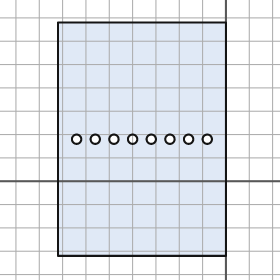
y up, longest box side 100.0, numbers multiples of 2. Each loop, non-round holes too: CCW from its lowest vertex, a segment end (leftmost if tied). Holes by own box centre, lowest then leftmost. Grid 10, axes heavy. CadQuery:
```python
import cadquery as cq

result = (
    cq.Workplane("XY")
    .moveTo(-72.0, -32.0)
    .lineTo(0.0, -32.0)
    .lineTo(0.0, 68.0)
    .lineTo(-72.0, 68.0)
    .close()
    .moveTo(-64.0, 18.0)
    .circle(2.0)
    .moveTo(-56.0, 18.0)
    .circle(2.0)
    .moveTo(-48.0, 18.0)
    .circle(2.0)
    .moveTo(-40.0, 18.0)
    .circle(2.0)
    .moveTo(-32.0, 18.0)
    .circle(2.0)
    .moveTo(-24.0, 18.0)
    .circle(2.0)
    .moveTo(-16.0, 18.0)
    .circle(2.0)
    .moveTo(-8.0, 18.0)
    .circle(2.0)
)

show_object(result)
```